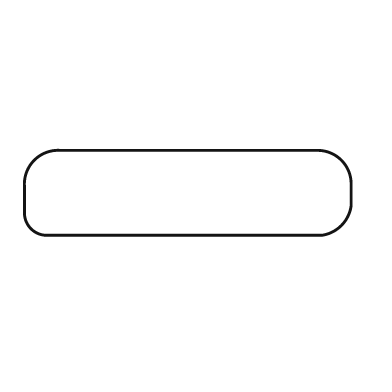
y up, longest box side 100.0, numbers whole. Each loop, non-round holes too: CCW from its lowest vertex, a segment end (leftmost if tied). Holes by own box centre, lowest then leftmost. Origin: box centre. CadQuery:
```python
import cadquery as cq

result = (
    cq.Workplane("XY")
    .moveTo(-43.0, -13.0)
    .lineTo(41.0, -13.0)
    .threePointArc((47.0, -10.0), (50.0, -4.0))
    .lineTo(50.0, 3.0)
    .threePointArc((47.0, 10.0), (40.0, 13.0))
    .lineTo(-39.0, 13.0)
    .threePointArc((-47.0, 10.0), (-50.0, 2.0))
    .lineTo(-50.0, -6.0)
    .threePointArc((-48.0, -11.0), (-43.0, -13.0))
    .close()
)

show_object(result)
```